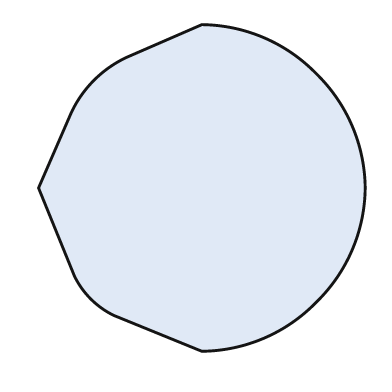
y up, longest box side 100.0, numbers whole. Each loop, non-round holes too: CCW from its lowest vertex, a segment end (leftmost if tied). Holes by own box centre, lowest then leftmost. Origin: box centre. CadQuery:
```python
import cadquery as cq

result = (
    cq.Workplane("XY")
    .moveTo(0.0, -50.0)
    .threePointArc((19.0, -46.0), (35.0, -35.0))
    .threePointArc((46.0, -19.0), (50.0, 0.0))
    .threePointArc((46.0, 19.0), (35.0, 35.0))
    .threePointArc((19.0, 46.0), (0.0, 50.0))
    .lineTo(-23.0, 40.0)
    .threePointArc((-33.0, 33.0), (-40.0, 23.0))
    .lineTo(-50.0, 0.0)
    .lineTo(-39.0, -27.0)
    .threePointArc((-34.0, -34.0), (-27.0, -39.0))
    .close()
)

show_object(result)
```